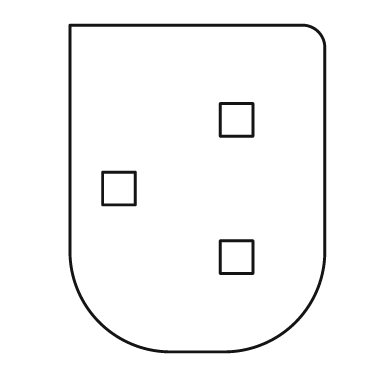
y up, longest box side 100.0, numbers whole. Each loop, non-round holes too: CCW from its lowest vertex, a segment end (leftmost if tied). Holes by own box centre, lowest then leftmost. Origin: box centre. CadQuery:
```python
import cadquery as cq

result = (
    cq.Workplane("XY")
    .moveTo(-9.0, -50.0)
    .lineTo(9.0, -50.0)
    .threePointArc((30.0, -41.0), (39.0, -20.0))
    .lineTo(39.0, 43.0)
    .threePointArc((37.0, 48.0), (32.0, 50.0))
    .lineTo(-39.0, 50.0)
    .lineTo(-39.0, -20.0)
    .threePointArc((-30.0, -41.0), (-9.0, -50.0))
    .close()
    .moveTo(7.0, -26.0)
    .lineTo(17.0, -26.0)
    .lineTo(17.0, -16.0)
    .lineTo(7.0, -16.0)
    .close()
    .moveTo(-29.0, -5.0)
    .lineTo(-19.0, -5.0)
    .lineTo(-19.0, 5.0)
    .lineTo(-29.0, 5.0)
    .close()
    .moveTo(7.0, 16.0)
    .lineTo(17.0, 16.0)
    .lineTo(17.0, 26.0)
    .lineTo(7.0, 26.0)
    .close()
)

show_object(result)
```